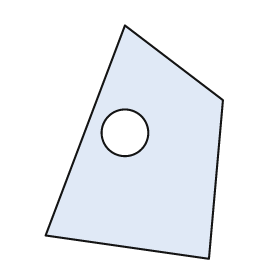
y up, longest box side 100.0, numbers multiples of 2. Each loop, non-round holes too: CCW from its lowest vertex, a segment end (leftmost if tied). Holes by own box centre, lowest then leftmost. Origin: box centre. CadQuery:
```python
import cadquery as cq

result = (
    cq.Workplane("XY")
    .moveTo(32.0, -50.0)
    .lineTo(38.0, 18.0)
    .lineTo(-4.0, 50.0)
    .lineTo(-38.0, -40.0)
    .close()
    .moveTo(-4.0, 4.0)
    .circle(10.0)
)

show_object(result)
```